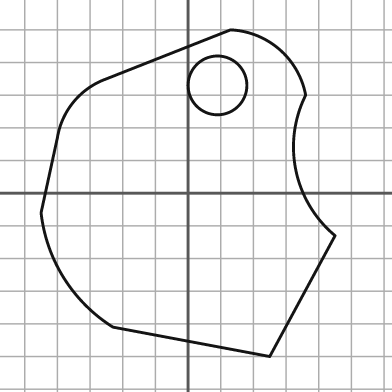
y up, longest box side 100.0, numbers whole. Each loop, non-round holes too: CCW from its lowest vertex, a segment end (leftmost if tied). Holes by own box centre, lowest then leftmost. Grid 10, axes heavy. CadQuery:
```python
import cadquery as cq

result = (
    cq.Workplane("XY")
    .moveTo(25.0, -50.0)
    .lineTo(45.0, -13.0)
    .threePointArc((33.0, 7.0), (36.0, 30.0))
    .threePointArc((28.0, 44.0), (13.0, 50.0))
    .lineTo(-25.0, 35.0)
    .threePointArc((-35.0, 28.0), (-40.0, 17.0))
    .lineTo(-45.0, -6.0)
    .threePointArc((-38.0, -26.0), (-23.0, -41.0))
    .close()
    .moveTo(9.0, 33.0)
    .circle(9.0)
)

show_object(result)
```